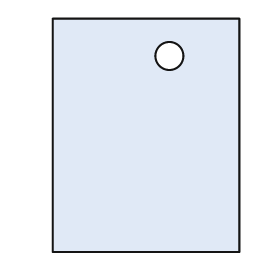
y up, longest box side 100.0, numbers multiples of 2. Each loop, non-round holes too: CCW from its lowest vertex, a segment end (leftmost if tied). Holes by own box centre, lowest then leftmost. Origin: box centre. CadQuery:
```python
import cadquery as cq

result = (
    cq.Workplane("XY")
    .moveTo(-40.0, -50.0)
    .lineTo(40.0, -50.0)
    .lineTo(40.0, 50.0)
    .lineTo(-40.0, 50.0)
    .close()
    .moveTo(10.0, 34.0)
    .circle(6.0)
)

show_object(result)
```